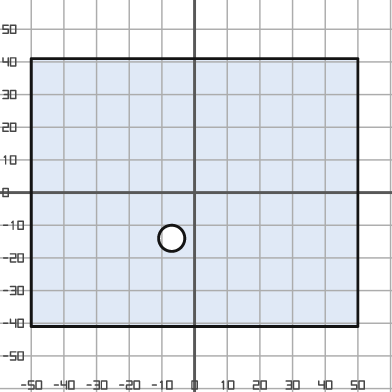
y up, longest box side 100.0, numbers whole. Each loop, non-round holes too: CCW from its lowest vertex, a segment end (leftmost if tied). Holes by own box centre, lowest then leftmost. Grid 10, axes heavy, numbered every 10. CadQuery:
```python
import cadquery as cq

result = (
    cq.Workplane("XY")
    .moveTo(-50.0, -41.0)
    .lineTo(50.0, -41.0)
    .lineTo(50.0, 41.0)
    .lineTo(-50.0, 41.0)
    .close()
    .moveTo(-7.0, -14.0)
    .circle(4.0)
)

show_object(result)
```